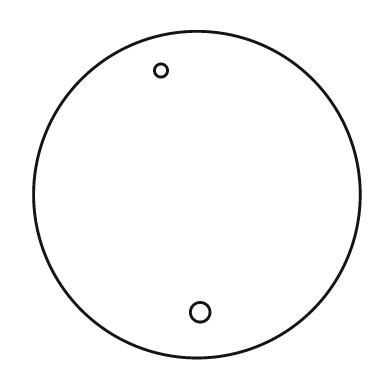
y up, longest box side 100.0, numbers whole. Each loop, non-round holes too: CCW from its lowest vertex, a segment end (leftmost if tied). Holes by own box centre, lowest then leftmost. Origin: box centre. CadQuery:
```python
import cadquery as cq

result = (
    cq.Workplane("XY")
    .moveTo(0.0, 0.0)
    .circle(50.0)
    .moveTo(1.0, -36.0)
    .circle(3.0)
    .moveTo(-11.0, 38.0)
    .circle(2.0)
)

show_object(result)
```